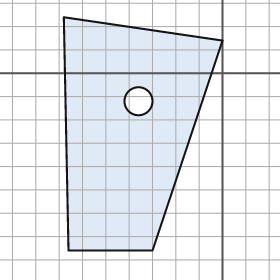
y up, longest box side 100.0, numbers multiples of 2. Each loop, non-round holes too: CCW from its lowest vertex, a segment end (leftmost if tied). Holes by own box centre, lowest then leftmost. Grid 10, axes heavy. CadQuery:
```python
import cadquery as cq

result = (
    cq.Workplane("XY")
    .moveTo(-66.0, -76.0)
    .lineTo(-30.0, -76.0)
    .lineTo(0.0, 14.0)
    .lineTo(-68.0, 24.0)
    .close()
    .moveTo(-36.0, -12.0)
    .circle(6.0)
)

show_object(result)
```